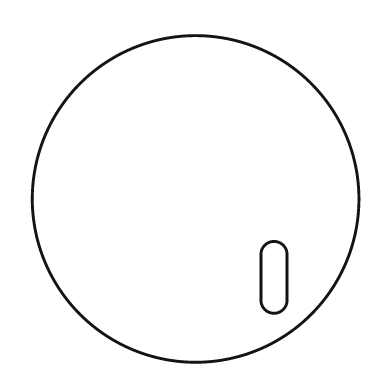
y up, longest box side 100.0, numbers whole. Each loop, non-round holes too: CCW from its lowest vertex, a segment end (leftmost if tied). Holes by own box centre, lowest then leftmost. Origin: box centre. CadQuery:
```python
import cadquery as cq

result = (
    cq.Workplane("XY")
    .moveTo(0.0, 0.0)
    .circle(50.0)
    .moveTo(20.0, -31.0)
    .threePointArc((24.0, -35.0), (28.0, -31.0))
    .lineTo(28.0, -17.0)
    .threePointArc((24.0, -13.0), (20.0, -17.0))
    .close()
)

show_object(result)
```